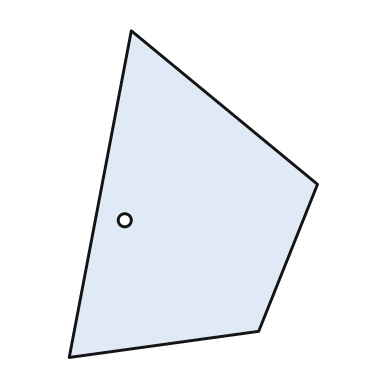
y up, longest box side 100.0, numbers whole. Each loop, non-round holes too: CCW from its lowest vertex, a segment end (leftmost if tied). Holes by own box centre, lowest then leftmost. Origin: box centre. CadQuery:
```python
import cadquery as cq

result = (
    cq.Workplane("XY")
    .moveTo(-38.0, -50.0)
    .lineTo(20.0, -42.0)
    .lineTo(38.0, 3.0)
    .lineTo(-19.0, 50.0)
    .close()
    .moveTo(-21.0, -8.0)
    .circle(2.0)
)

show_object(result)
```